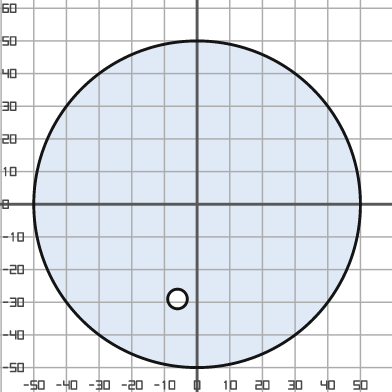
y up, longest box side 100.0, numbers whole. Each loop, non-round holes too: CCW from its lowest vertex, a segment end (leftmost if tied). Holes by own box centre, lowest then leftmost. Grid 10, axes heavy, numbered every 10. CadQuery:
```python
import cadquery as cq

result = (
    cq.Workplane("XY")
    .moveTo(0.0, 0.0)
    .circle(50.0)
    .moveTo(-6.0, -29.0)
    .circle(3.0)
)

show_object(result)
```